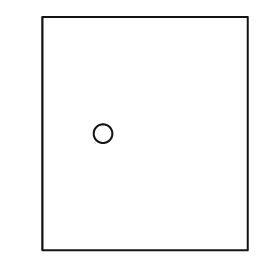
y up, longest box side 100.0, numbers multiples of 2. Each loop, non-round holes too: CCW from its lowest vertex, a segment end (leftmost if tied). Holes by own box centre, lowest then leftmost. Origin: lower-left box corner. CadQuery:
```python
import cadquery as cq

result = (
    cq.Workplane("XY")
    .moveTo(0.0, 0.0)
    .lineTo(88.0, 0.0)
    .lineTo(88.0, 100.0)
    .lineTo(0.0, 100.0)
    .close()
    .moveTo(26.0, 50.0)
    .circle(4.0)
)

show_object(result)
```